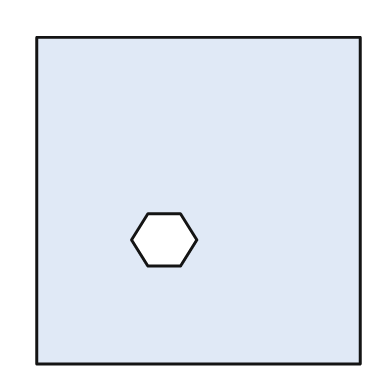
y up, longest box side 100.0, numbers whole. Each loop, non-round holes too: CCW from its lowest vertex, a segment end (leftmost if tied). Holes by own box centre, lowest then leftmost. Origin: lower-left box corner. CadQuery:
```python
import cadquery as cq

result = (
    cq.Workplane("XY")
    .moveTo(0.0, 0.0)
    .lineTo(99.0, 0.0)
    .lineTo(99.0, 100.0)
    .lineTo(0.0, 100.0)
    .close()
    .moveTo(34.0, 30.0)
    .lineTo(44.0, 30.0)
    .lineTo(49.0, 38.0)
    .lineTo(44.0, 46.0)
    .lineTo(34.0, 46.0)
    .lineTo(29.0, 38.0)
    .close()
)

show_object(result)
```